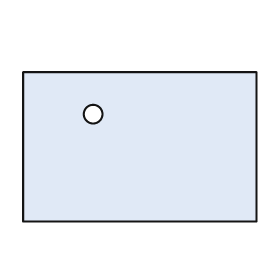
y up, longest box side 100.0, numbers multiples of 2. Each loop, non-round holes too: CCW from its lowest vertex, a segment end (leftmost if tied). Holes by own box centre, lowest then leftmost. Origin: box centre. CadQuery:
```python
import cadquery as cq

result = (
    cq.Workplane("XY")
    .moveTo(-50.0, -32.0)
    .lineTo(50.0, -32.0)
    .lineTo(50.0, 32.0)
    .lineTo(-50.0, 32.0)
    .close()
    .moveTo(-20.0, 14.0)
    .circle(4.0)
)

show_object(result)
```